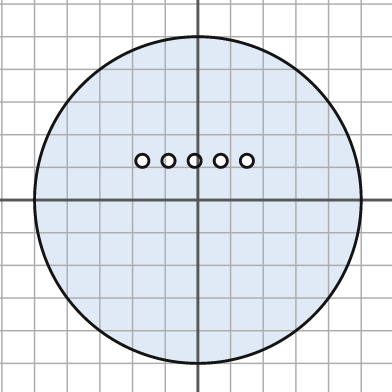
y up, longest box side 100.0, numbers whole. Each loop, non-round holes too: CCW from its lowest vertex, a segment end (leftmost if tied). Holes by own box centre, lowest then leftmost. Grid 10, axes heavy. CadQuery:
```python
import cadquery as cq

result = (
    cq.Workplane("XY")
    .moveTo(0.0, 0.0)
    .circle(50.0)
    .moveTo(-17.0, 12.0)
    .circle(2.0)
    .moveTo(-9.0, 12.0)
    .circle(2.0)
    .moveTo(-1.0, 12.0)
    .circle(2.0)
    .moveTo(7.0, 12.0)
    .circle(2.0)
    .moveTo(15.0, 12.0)
    .circle(2.0)
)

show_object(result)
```